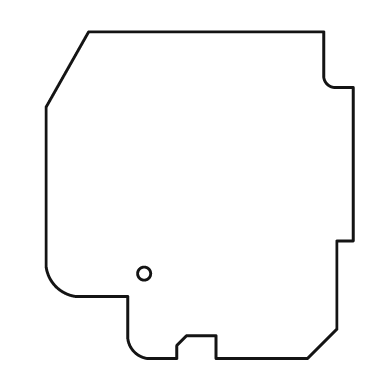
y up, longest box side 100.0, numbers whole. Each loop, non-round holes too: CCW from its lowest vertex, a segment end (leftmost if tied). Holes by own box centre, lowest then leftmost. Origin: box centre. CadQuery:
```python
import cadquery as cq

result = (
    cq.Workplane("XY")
    .moveTo(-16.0, -50.0)
    .lineTo(-7.0, -50.0)
    .lineTo(-7.0, -46.0)
    .lineTo(-4.0, -43.0)
    .lineTo(5.0, -43.0)
    .lineTo(5.0, -50.0)
    .lineTo(33.0, -50.0)
    .lineTo(42.0, -41.0)
    .lineTo(42.0, -14.0)
    .lineTo(47.0, -14.0)
    .lineTo(47.0, 33.0)
    .lineTo(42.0, 33.0)
    .threePointArc((39.0, 34.0), (38.0, 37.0))
    .lineTo(38.0, 50.0)
    .lineTo(-34.0, 50.0)
    .lineTo(-47.0, 27.0)
    .lineTo(-47.0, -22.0)
    .threePointArc((-44.0, -28.0), (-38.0, -31.0))
    .lineTo(-22.0, -31.0)
    .lineTo(-22.0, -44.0)
    .threePointArc((-20.0, -48.0), (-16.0, -50.0))
    .close()
    .moveTo(-17.0, -24.0)
    .circle(2.0)
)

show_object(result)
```